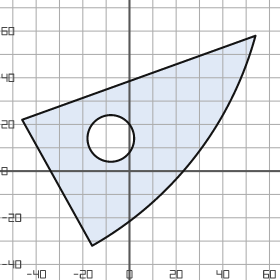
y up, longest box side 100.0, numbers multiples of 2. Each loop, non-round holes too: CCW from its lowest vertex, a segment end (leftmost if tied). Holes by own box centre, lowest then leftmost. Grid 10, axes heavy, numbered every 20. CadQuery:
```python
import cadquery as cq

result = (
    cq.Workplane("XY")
    .moveTo(-16.0, -32.0)
    .threePointArc((28.0, 6.0), (54.0, 58.0))
    .lineTo(-46.0, 22.0)
    .close()
    .moveTo(-8.0, 14.0)
    .circle(10.0)
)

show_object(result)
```